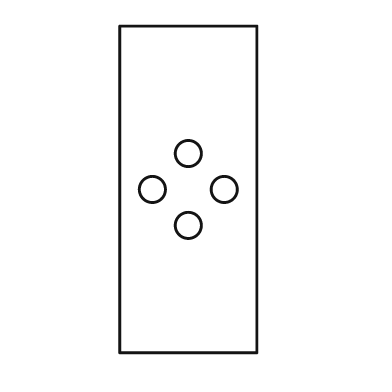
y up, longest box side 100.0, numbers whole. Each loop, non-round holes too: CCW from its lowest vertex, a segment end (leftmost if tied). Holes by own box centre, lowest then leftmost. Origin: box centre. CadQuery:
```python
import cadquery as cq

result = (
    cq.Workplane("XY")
    .moveTo(-21.0, -50.0)
    .lineTo(21.0, -50.0)
    .lineTo(21.0, 50.0)
    .lineTo(-21.0, 50.0)
    .close()
    .moveTo(0.0, -11.0)
    .circle(4.0)
    .moveTo(-11.0, 0.0)
    .circle(4.0)
    .moveTo(11.0, 0.0)
    .circle(4.0)
    .moveTo(0.0, 11.0)
    .circle(4.0)
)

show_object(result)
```